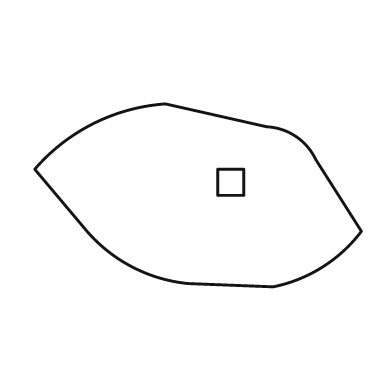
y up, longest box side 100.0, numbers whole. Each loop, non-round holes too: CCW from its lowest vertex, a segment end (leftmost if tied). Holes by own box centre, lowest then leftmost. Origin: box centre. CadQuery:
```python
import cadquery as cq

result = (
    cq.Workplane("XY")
    .moveTo(23.0, -28.0)
    .threePointArc((38.0, -22.0), (50.0, -11.0))
    .lineTo(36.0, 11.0)
    .threePointArc((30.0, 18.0), (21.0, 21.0))
    .lineTo(-10.0, 28.0)
    .threePointArc((-32.0, 22.0), (-50.0, 8.0))
    .lineTo(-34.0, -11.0)
    .threePointArc((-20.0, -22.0), (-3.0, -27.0))
    .close()
    .moveTo(6.0, 0.0)
    .lineTo(14.0, 0.0)
    .lineTo(14.0, 8.0)
    .lineTo(6.0, 8.0)
    .close()
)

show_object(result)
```